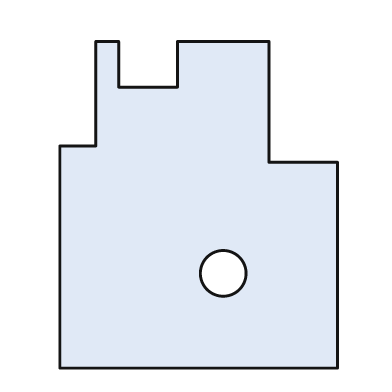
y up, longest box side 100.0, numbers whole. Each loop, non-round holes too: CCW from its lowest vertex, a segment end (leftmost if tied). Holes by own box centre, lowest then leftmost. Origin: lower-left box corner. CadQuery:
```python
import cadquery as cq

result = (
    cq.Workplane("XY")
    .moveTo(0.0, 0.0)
    .lineTo(85.0, 0.0)
    .lineTo(85.0, 63.0)
    .lineTo(64.0, 63.0)
    .lineTo(64.0, 100.0)
    .lineTo(36.0, 100.0)
    .lineTo(36.0, 86.0)
    .lineTo(18.0, 86.0)
    .lineTo(18.0, 100.0)
    .lineTo(11.0, 100.0)
    .lineTo(11.0, 68.0)
    .lineTo(0.0, 68.0)
    .close()
    .moveTo(50.0, 29.0)
    .circle(7.0)
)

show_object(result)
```